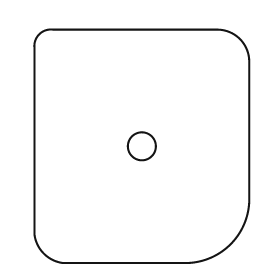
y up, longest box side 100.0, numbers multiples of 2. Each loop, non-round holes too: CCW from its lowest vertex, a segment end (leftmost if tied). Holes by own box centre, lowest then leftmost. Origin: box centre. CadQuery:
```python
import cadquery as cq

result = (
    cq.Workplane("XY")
    .moveTo(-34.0, -50.0)
    .lineTo(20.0, -50.0)
    .threePointArc((38.0, -42.0), (46.0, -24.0))
    .lineTo(46.0, 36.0)
    .threePointArc((42.0, 46.0), (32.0, 50.0))
    .lineTo(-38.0, 50.0)
    .threePointArc((-44.0, 48.0), (-46.0, 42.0))
    .lineTo(-46.0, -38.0)
    .threePointArc((-42.0, -46.0), (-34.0, -50.0))
    .close()
    .moveTo(0.0, 0.0)
    .circle(6.0)
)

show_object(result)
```